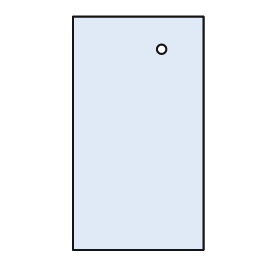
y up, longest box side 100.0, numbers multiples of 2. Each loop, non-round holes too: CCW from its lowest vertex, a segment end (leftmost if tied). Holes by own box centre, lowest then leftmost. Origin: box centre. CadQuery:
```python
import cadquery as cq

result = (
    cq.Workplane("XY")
    .moveTo(-28.0, -50.0)
    .lineTo(28.0, -50.0)
    .lineTo(28.0, 50.0)
    .lineTo(-28.0, 50.0)
    .close()
    .moveTo(10.0, 36.0)
    .circle(2.0)
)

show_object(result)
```